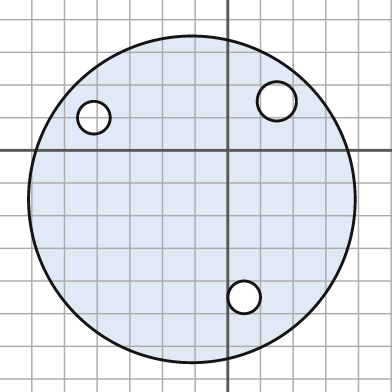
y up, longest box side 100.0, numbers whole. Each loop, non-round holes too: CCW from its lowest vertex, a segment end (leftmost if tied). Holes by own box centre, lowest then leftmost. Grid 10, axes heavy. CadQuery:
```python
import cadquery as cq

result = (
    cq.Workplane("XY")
    .moveTo(-11.0, -15.0)
    .circle(50.0)
    .moveTo(5.0, -45.0)
    .circle(5.0)
    .moveTo(-41.0, 10.0)
    .circle(5.0)
    .moveTo(15.0, 15.0)
    .circle(6.0)
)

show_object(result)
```